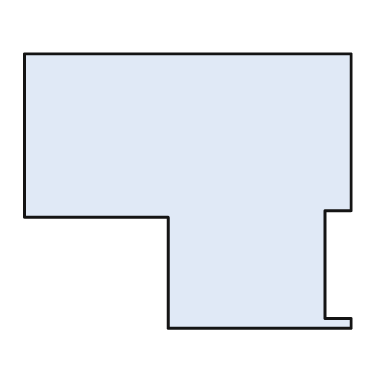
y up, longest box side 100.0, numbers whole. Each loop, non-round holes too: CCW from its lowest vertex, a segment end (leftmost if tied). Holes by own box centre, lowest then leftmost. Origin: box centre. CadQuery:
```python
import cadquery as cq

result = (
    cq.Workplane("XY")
    .moveTo(-6.0, -42.0)
    .lineTo(50.0, -42.0)
    .lineTo(50.0, -39.0)
    .lineTo(42.0, -39.0)
    .lineTo(42.0, -6.0)
    .lineTo(50.0, -6.0)
    .lineTo(50.0, 42.0)
    .lineTo(-50.0, 42.0)
    .lineTo(-50.0, -8.0)
    .lineTo(-6.0, -8.0)
    .close()
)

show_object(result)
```